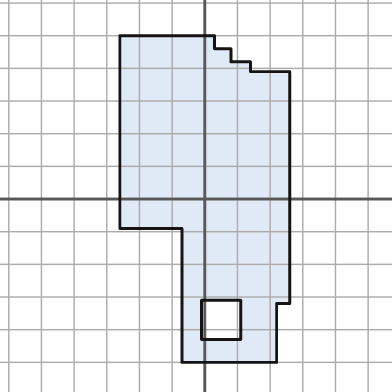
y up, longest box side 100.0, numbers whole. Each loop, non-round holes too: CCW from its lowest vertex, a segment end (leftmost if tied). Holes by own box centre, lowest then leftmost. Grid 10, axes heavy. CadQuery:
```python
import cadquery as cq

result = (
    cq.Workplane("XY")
    .moveTo(-7.0, -50.0)
    .lineTo(22.0, -50.0)
    .lineTo(22.0, -32.0)
    .lineTo(26.0, -32.0)
    .lineTo(26.0, 39.0)
    .lineTo(14.0, 39.0)
    .lineTo(14.0, 42.0)
    .lineTo(8.0, 42.0)
    .lineTo(8.0, 46.0)
    .lineTo(3.0, 46.0)
    .lineTo(3.0, 50.0)
    .lineTo(-26.0, 50.0)
    .lineTo(-26.0, -9.0)
    .lineTo(-7.0, -9.0)
    .close()
    .moveTo(-1.0, -43.0)
    .lineTo(11.0, -43.0)
    .lineTo(11.0, -31.0)
    .lineTo(-1.0, -31.0)
    .close()
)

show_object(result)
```